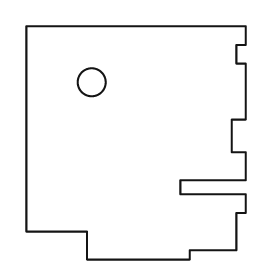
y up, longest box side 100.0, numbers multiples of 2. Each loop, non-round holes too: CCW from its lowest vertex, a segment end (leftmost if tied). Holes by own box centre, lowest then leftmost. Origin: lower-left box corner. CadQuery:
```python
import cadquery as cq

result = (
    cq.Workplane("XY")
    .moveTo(26.0, 0.0)
    .lineTo(70.0, 0.0)
    .lineTo(70.0, 4.0)
    .lineTo(90.0, 4.0)
    .lineTo(90.0, 20.0)
    .lineTo(94.0, 20.0)
    .lineTo(94.0, 28.0)
    .lineTo(66.0, 28.0)
    .lineTo(66.0, 34.0)
    .lineTo(94.0, 34.0)
    .lineTo(94.0, 46.0)
    .lineTo(88.0, 46.0)
    .lineTo(88.0, 60.0)
    .lineTo(94.0, 60.0)
    .lineTo(94.0, 84.0)
    .lineTo(90.0, 84.0)
    .lineTo(90.0, 92.0)
    .lineTo(94.0, 92.0)
    .lineTo(94.0, 100.0)
    .lineTo(0.0, 100.0)
    .lineTo(0.0, 12.0)
    .lineTo(26.0, 12.0)
    .close()
    .moveTo(28.0, 76.0)
    .circle(6.0)
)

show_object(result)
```